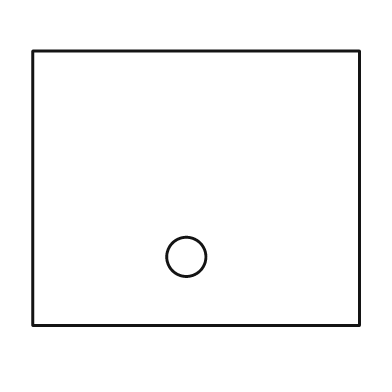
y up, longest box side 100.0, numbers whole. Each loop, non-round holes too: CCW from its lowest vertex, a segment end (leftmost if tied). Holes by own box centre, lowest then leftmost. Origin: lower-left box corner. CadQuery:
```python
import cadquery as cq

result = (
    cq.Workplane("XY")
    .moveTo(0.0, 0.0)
    .lineTo(100.0, 0.0)
    .lineTo(100.0, 84.0)
    .lineTo(0.0, 84.0)
    .close()
    .moveTo(47.0, 21.0)
    .circle(6.0)
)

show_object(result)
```